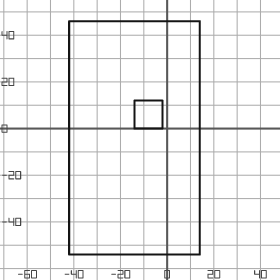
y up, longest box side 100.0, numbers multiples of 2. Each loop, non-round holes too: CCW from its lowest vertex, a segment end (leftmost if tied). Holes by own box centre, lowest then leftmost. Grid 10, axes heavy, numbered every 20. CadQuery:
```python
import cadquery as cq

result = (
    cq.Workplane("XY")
    .moveTo(-42.0, -54.0)
    .lineTo(14.0, -54.0)
    .lineTo(14.0, 46.0)
    .lineTo(-42.0, 46.0)
    .close()
    .moveTo(-14.0, 0.0)
    .lineTo(-2.0, 0.0)
    .lineTo(-2.0, 12.0)
    .lineTo(-14.0, 12.0)
    .close()
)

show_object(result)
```